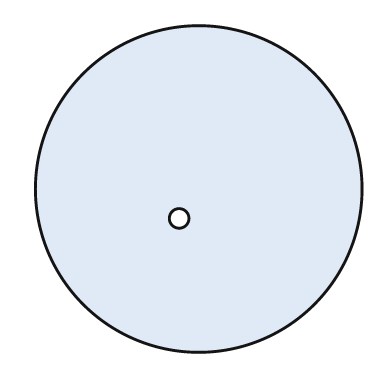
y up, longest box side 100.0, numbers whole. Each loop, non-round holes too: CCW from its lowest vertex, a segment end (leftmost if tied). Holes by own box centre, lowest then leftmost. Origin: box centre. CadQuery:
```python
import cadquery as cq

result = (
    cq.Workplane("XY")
    .moveTo(0.0, 0.0)
    .circle(50.0)
    .moveTo(-6.0, -9.0)
    .circle(3.0)
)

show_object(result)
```